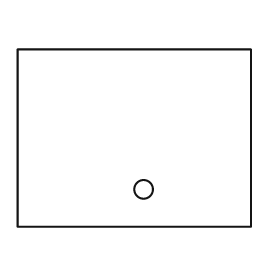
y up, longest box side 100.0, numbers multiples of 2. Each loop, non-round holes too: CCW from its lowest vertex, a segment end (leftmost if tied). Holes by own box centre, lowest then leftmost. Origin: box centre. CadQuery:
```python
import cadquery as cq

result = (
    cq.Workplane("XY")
    .moveTo(-50.0, -38.0)
    .lineTo(50.0, -38.0)
    .lineTo(50.0, 38.0)
    .lineTo(-50.0, 38.0)
    .close()
    .moveTo(4.0, -22.0)
    .circle(4.0)
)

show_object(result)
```